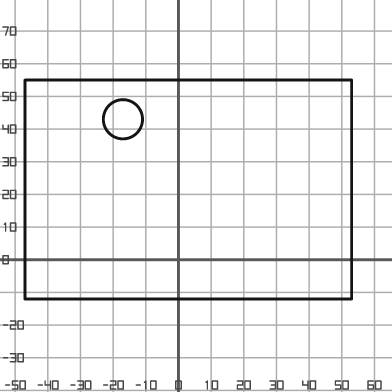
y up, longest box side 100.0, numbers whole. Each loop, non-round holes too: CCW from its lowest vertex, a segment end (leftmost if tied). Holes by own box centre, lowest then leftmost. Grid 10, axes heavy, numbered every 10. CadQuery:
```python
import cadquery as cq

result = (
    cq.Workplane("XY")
    .moveTo(-47.0, -12.0)
    .lineTo(53.0, -12.0)
    .lineTo(53.0, 55.0)
    .lineTo(-47.0, 55.0)
    .close()
    .moveTo(-17.0, 43.0)
    .circle(6.0)
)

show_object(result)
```